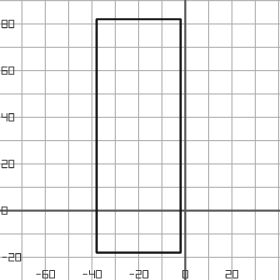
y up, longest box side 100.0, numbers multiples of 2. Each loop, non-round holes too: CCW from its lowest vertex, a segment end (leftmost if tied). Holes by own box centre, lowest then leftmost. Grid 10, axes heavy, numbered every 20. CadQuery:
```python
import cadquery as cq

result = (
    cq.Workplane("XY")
    .moveTo(-38.0, -18.0)
    .lineTo(-2.0, -18.0)
    .lineTo(-2.0, 82.0)
    .lineTo(-38.0, 82.0)
    .close()
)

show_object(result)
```